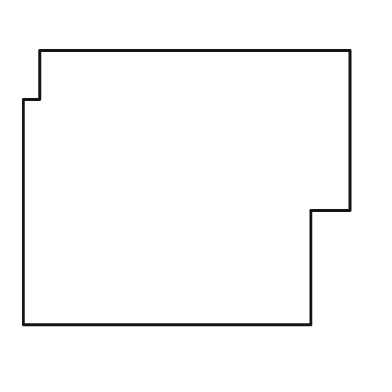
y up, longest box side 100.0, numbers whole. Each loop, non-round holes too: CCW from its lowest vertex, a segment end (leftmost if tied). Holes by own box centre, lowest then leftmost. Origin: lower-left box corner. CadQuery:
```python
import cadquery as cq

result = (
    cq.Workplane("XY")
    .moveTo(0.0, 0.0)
    .lineTo(88.0, 0.0)
    .lineTo(88.0, 35.0)
    .lineTo(100.0, 35.0)
    .lineTo(100.0, 84.0)
    .lineTo(5.0, 84.0)
    .lineTo(5.0, 69.0)
    .lineTo(0.0, 69.0)
    .close()
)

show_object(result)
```